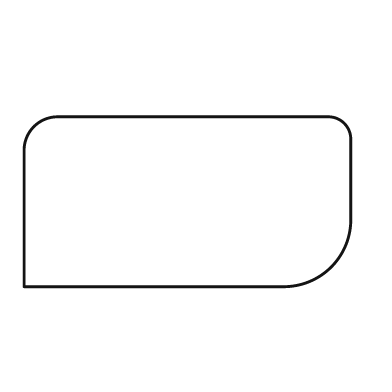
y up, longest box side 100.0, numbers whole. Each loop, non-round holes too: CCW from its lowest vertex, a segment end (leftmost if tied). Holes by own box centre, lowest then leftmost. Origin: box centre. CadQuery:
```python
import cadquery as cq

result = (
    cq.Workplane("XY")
    .moveTo(-50.0, -26.0)
    .lineTo(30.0, -26.0)
    .threePointArc((44.0, -20.0), (50.0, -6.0))
    .lineTo(50.0, 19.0)
    .threePointArc((48.0, 24.0), (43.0, 26.0))
    .lineTo(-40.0, 26.0)
    .threePointArc((-47.0, 23.0), (-50.0, 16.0))
    .close()
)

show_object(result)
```